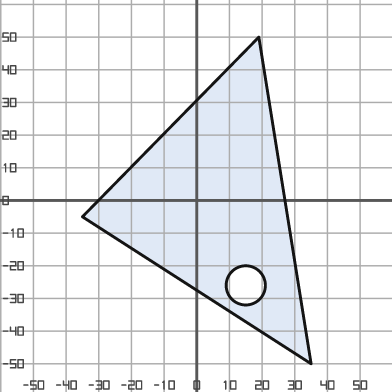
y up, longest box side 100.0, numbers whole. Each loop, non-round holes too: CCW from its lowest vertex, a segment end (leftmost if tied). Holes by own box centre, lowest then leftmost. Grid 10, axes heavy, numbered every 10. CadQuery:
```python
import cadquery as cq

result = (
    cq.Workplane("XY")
    .moveTo(35.0, -50.0)
    .lineTo(19.0, 50.0)
    .lineTo(-35.0, -5.0)
    .close()
    .moveTo(15.0, -26.0)
    .circle(6.0)
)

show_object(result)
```